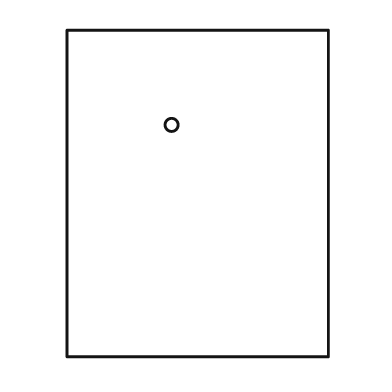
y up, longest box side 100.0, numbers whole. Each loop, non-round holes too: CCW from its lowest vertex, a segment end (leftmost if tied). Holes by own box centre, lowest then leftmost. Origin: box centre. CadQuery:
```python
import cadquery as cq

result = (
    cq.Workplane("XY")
    .moveTo(-40.0, -50.0)
    .lineTo(40.0, -50.0)
    .lineTo(40.0, 50.0)
    .lineTo(-40.0, 50.0)
    .close()
    .moveTo(-8.0, 21.0)
    .circle(2.0)
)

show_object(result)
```